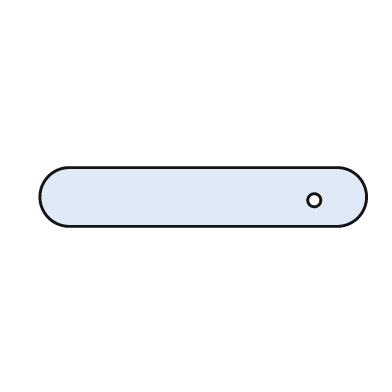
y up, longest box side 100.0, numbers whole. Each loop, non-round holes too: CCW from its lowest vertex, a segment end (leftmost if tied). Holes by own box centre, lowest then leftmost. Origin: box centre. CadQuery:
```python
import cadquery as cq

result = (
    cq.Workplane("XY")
    .moveTo(-41.0, -9.0)
    .lineTo(41.0, -9.0)
    .threePointArc((50.0, 0.0), (41.0, 9.0))
    .lineTo(-41.0, 9.0)
    .threePointArc((-50.0, 0.0), (-41.0, -9.0))
    .close()
    .moveTo(34.0, -1.0)
    .circle(2.0)
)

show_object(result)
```